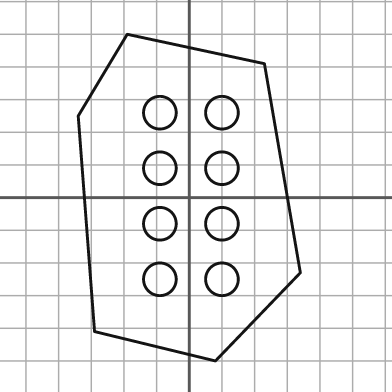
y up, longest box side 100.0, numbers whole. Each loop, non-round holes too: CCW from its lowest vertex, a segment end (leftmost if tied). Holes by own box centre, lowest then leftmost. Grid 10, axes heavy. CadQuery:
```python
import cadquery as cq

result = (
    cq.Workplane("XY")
    .moveTo(8.0, -50.0)
    .lineTo(34.0, -23.0)
    .lineTo(23.0, 41.0)
    .lineTo(-19.0, 50.0)
    .lineTo(-34.0, 25.0)
    .lineTo(-29.0, -41.0)
    .close()
    .moveTo(-9.0, -25.0)
    .circle(5.0)
    .moveTo(10.0, -25.0)
    .circle(5.0)
    .moveTo(-9.0, -8.0)
    .circle(5.0)
    .moveTo(10.0, -8.0)
    .circle(5.0)
    .moveTo(-9.0, 9.0)
    .circle(5.0)
    .moveTo(10.0, 9.0)
    .circle(5.0)
    .moveTo(-9.0, 26.0)
    .circle(5.0)
    .moveTo(10.0, 26.0)
    .circle(5.0)
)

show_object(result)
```